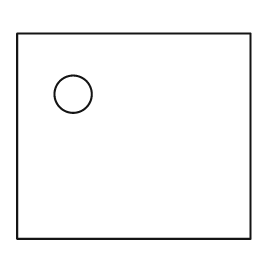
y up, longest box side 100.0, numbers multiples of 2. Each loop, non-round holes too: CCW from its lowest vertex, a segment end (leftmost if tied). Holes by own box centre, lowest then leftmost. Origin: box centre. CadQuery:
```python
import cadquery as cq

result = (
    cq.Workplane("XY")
    .moveTo(-50.0, -44.0)
    .lineTo(50.0, -44.0)
    .lineTo(50.0, 44.0)
    .lineTo(-50.0, 44.0)
    .close()
    .moveTo(-26.0, 18.0)
    .circle(8.0)
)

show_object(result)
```